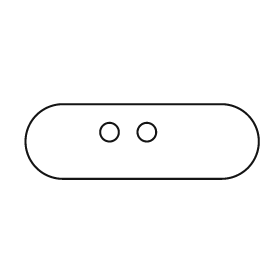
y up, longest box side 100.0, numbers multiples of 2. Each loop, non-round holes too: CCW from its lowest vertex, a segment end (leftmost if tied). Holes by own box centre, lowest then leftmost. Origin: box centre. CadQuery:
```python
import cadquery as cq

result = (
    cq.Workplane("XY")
    .moveTo(-34.0, -16.0)
    .lineTo(34.0, -16.0)
    .threePointArc((50.0, 0.0), (34.0, 16.0))
    .lineTo(-34.0, 16.0)
    .threePointArc((-50.0, 0.0), (-34.0, -16.0))
    .close()
    .moveTo(-14.0, 4.0)
    .circle(4.0)
    .moveTo(2.0, 4.0)
    .circle(4.0)
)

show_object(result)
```